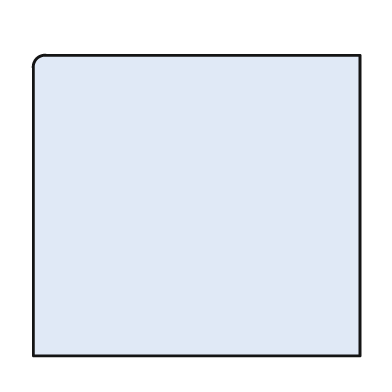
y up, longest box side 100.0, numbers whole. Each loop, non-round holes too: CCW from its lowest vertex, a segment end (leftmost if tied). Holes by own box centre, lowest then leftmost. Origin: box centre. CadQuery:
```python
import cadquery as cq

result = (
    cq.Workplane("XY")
    .moveTo(-50.0, -46.0)
    .lineTo(50.0, -46.0)
    .lineTo(50.0, 46.0)
    .lineTo(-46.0, 46.0)
    .threePointArc((-49.0, 45.0), (-50.0, 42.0))
    .close()
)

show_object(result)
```